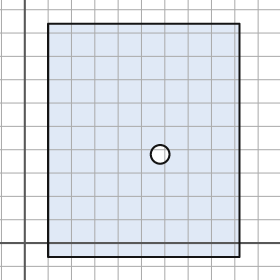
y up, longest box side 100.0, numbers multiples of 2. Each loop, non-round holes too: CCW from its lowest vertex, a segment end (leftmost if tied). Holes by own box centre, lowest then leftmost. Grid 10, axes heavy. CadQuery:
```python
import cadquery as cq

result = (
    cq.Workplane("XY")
    .moveTo(10.0, -6.0)
    .lineTo(92.0, -6.0)
    .lineTo(92.0, 94.0)
    .lineTo(10.0, 94.0)
    .close()
    .moveTo(58.0, 38.0)
    .circle(4.0)
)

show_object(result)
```